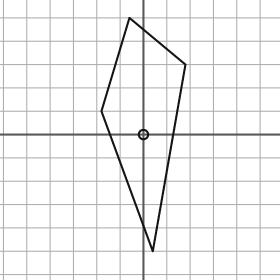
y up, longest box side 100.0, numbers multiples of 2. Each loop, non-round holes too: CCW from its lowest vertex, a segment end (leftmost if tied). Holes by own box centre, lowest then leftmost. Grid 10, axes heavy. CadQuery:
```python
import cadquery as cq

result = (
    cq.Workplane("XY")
    .moveTo(4.0, -50.0)
    .lineTo(18.0, 30.0)
    .lineTo(-6.0, 50.0)
    .lineTo(-18.0, 10.0)
    .close()
    .moveTo(0.0, 0.0)
    .circle(2.0)
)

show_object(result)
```